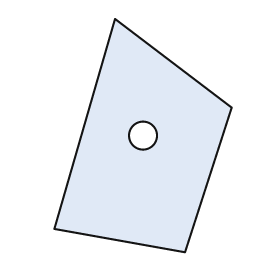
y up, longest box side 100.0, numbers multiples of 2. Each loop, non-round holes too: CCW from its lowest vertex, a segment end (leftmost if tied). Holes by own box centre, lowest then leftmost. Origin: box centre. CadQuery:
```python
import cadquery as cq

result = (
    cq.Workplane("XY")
    .moveTo(18.0, -50.0)
    .lineTo(38.0, 12.0)
    .lineTo(-12.0, 50.0)
    .lineTo(-38.0, -40.0)
    .close()
    .moveTo(0.0, 0.0)
    .circle(6.0)
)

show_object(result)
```